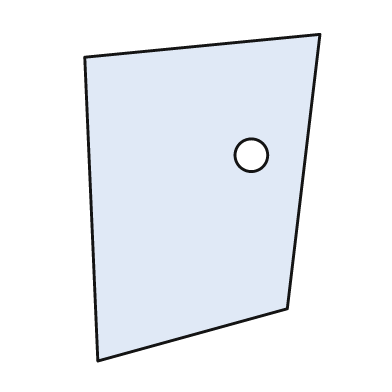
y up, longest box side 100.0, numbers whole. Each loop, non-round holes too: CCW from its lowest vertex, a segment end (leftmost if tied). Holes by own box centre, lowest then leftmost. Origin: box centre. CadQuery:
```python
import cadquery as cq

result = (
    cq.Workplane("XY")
    .moveTo(-32.0, -50.0)
    .lineTo(26.0, -34.0)
    .lineTo(36.0, 50.0)
    .lineTo(-36.0, 43.0)
    .close()
    .moveTo(15.0, 13.0)
    .circle(5.0)
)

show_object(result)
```